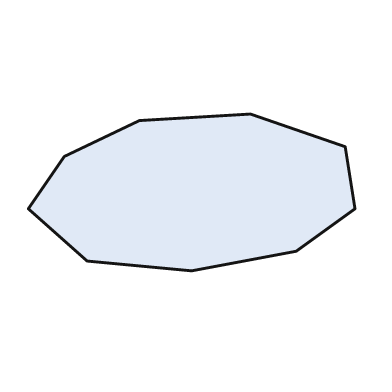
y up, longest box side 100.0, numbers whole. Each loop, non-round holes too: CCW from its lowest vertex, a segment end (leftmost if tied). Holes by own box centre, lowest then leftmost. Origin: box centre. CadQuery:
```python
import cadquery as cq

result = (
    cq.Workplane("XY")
    .moveTo(0.0, -24.0)
    .lineTo(32.0, -18.0)
    .lineTo(50.0, -5.0)
    .lineTo(47.0, 14.0)
    .lineTo(18.0, 24.0)
    .lineTo(-16.0, 22.0)
    .lineTo(-39.0, 11.0)
    .lineTo(-50.0, -5.0)
    .lineTo(-32.0, -21.0)
    .close()
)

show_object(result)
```